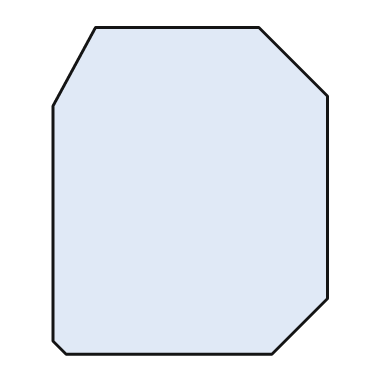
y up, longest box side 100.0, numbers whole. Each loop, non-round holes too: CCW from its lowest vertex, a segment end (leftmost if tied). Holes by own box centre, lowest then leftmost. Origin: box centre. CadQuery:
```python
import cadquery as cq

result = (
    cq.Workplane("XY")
    .moveTo(-38.0, -50.0)
    .lineTo(25.0, -50.0)
    .lineTo(42.0, -33.0)
    .lineTo(42.0, 29.0)
    .lineTo(21.0, 50.0)
    .lineTo(-29.0, 50.0)
    .lineTo(-42.0, 26.0)
    .lineTo(-42.0, -46.0)
    .close()
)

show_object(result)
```